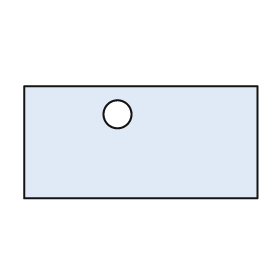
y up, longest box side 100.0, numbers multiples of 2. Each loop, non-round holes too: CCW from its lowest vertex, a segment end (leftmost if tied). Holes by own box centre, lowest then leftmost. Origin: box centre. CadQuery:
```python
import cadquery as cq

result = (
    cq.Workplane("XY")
    .moveTo(-50.0, -24.0)
    .lineTo(50.0, -24.0)
    .lineTo(50.0, 24.0)
    .lineTo(-50.0, 24.0)
    .close()
    .moveTo(-10.0, 12.0)
    .circle(6.0)
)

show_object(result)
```